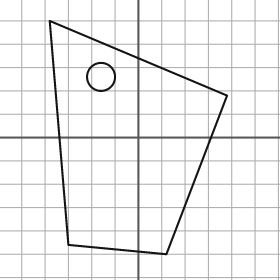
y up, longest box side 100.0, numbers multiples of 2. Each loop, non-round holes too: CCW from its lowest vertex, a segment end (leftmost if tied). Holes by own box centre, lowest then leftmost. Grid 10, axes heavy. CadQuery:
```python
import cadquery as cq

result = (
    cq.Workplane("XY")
    .moveTo(12.0, -50.0)
    .lineTo(38.0, 18.0)
    .lineTo(-38.0, 50.0)
    .lineTo(-30.0, -46.0)
    .close()
    .moveTo(-16.0, 26.0)
    .circle(6.0)
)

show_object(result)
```